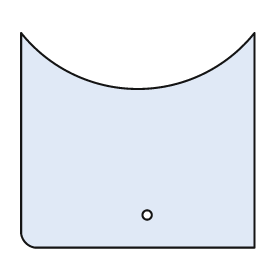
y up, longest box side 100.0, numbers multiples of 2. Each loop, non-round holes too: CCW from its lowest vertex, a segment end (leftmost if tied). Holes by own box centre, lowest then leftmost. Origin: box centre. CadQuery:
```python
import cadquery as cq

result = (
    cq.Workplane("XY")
    .moveTo(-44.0, -46.0)
    .lineTo(50.0, -46.0)
    .lineTo(50.0, 46.0)
    .threePointArc((0.0, 22.0), (-50.0, 46.0))
    .lineTo(-50.0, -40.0)
    .threePointArc((-48.0, -44.0), (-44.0, -46.0))
    .close()
    .moveTo(4.0, -32.0)
    .circle(2.0)
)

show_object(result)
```